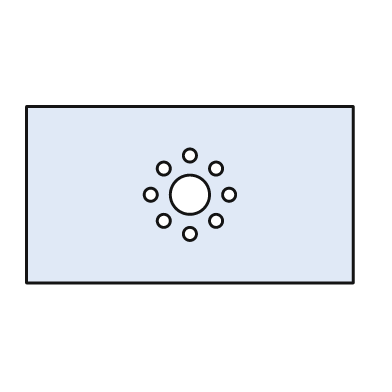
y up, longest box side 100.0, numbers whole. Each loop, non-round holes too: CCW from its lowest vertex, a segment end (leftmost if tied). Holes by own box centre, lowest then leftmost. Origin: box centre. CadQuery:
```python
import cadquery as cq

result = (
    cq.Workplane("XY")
    .moveTo(-50.0, -27.0)
    .lineTo(50.0, -27.0)
    .lineTo(50.0, 27.0)
    .lineTo(-50.0, 27.0)
    .close()
    .moveTo(0.0, -12.0)
    .circle(2.0)
    .moveTo(-8.0, -8.0)
    .circle(2.0)
    .moveTo(8.0, -8.0)
    .circle(2.0)
    .moveTo(-12.0, 0.0)
    .circle(2.0)
    .moveTo(0.0, 0.0)
    .circle(6.0)
    .moveTo(12.0, 0.0)
    .circle(2.0)
    .moveTo(-8.0, 8.0)
    .circle(2.0)
    .moveTo(8.0, 8.0)
    .circle(2.0)
    .moveTo(0.0, 12.0)
    .circle(2.0)
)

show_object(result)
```